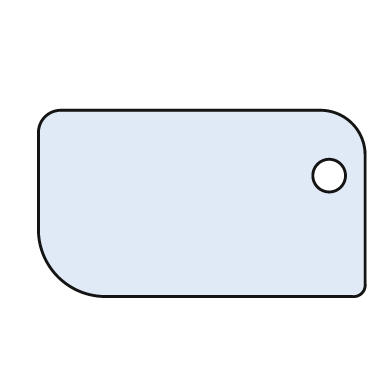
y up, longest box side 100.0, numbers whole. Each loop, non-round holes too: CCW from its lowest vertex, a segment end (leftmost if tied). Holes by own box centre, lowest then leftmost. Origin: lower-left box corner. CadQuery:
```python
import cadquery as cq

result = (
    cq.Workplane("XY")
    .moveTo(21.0, 0.0)
    .lineTo(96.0, 0.0)
    .threePointArc((99.0, 1.0), (100.0, 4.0))
    .lineTo(100.0, 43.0)
    .threePointArc((96.0, 53.0), (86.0, 57.0))
    .lineTo(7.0, 57.0)
    .threePointArc((2.0, 55.0), (0.0, 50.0))
    .lineTo(0.0, 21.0)
    .threePointArc((6.0, 6.0), (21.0, 0.0))
    .close()
    .moveTo(89.0, 37.0)
    .circle(5.0)
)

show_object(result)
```